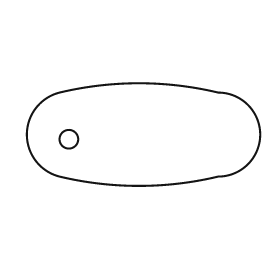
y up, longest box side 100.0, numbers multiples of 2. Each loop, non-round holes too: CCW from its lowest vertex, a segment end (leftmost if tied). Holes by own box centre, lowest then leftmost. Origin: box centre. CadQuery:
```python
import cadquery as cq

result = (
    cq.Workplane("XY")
    .moveTo(-36.0, -18.0)
    .threePointArc((-2.0, -22.0), (32.0, -18.0))
    .threePointArc((50.0, 0.0), (32.0, 18.0))
    .threePointArc((-2.0, 22.0), (-36.0, 18.0))
    .threePointArc((-50.0, 0.0), (-36.0, -18.0))
    .close()
    .moveTo(-32.0, -2.0)
    .circle(4.0)
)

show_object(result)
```